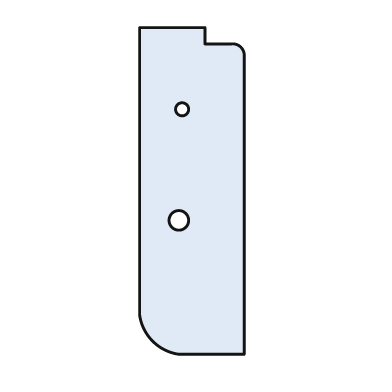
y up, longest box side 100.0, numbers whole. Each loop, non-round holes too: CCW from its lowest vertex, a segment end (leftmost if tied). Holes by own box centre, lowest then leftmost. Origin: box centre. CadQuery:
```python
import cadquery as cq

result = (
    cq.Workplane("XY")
    .moveTo(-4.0, -50.0)
    .lineTo(16.0, -50.0)
    .lineTo(16.0, 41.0)
    .threePointArc((15.0, 44.0), (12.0, 45.0))
    .lineTo(4.0, 45.0)
    .lineTo(4.0, 50.0)
    .lineTo(-16.0, 50.0)
    .lineTo(-16.0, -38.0)
    .threePointArc((-12.0, -46.0), (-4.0, -50.0))
    .close()
    .moveTo(-4.0, -9.0)
    .circle(3.0)
    .moveTo(-3.0, 25.0)
    .circle(2.0)
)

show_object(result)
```